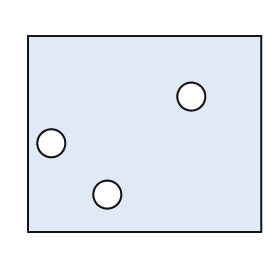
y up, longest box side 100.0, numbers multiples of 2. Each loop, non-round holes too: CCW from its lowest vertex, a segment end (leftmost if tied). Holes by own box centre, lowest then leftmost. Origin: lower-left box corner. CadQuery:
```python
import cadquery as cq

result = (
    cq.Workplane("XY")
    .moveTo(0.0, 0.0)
    .lineTo(100.0, 0.0)
    .lineTo(100.0, 84.0)
    .lineTo(0.0, 84.0)
    .close()
    .moveTo(34.0, 16.0)
    .circle(6.0)
    .moveTo(10.0, 38.0)
    .circle(6.0)
    .moveTo(70.0, 58.0)
    .circle(6.0)
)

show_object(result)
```